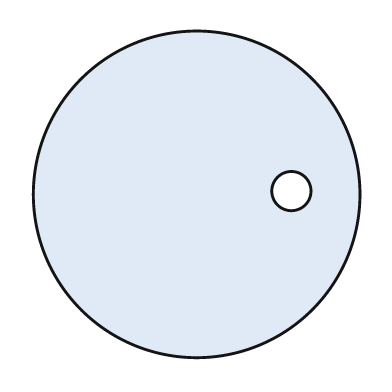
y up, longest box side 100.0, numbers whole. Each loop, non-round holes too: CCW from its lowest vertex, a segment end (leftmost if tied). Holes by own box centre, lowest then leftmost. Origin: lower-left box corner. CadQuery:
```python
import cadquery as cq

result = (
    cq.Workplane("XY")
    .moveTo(50.0, 50.0)
    .circle(50.0)
    .moveTo(79.0, 51.0)
    .circle(6.0)
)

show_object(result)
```